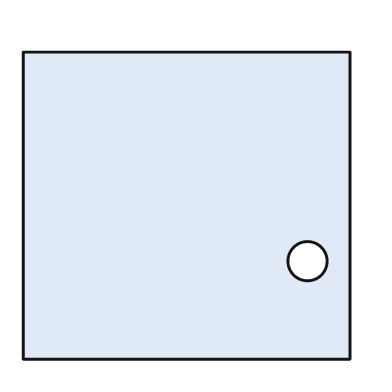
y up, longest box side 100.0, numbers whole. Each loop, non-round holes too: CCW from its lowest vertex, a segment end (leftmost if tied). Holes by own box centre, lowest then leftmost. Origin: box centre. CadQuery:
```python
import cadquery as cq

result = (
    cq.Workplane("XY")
    .moveTo(-50.0, -47.0)
    .lineTo(50.0, -47.0)
    .lineTo(50.0, 47.0)
    .lineTo(-50.0, 47.0)
    .close()
    .moveTo(37.0, -17.0)
    .circle(6.0)
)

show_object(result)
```